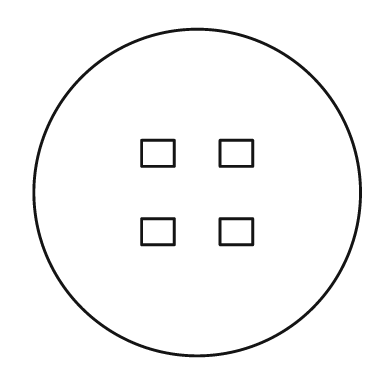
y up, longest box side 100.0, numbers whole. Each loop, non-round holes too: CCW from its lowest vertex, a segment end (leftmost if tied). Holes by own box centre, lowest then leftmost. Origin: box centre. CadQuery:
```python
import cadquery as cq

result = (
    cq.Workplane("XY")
    .moveTo(0.0, 0.0)
    .circle(50.0)
    .moveTo(-17.0, -16.0)
    .lineTo(-7.0, -16.0)
    .lineTo(-7.0, -8.0)
    .lineTo(-17.0, -8.0)
    .close()
    .moveTo(7.0, -16.0)
    .lineTo(17.0, -16.0)
    .lineTo(17.0, -8.0)
    .lineTo(7.0, -8.0)
    .close()
    .moveTo(-17.0, 8.0)
    .lineTo(-7.0, 8.0)
    .lineTo(-7.0, 16.0)
    .lineTo(-17.0, 16.0)
    .close()
    .moveTo(7.0, 8.0)
    .lineTo(17.0, 8.0)
    .lineTo(17.0, 16.0)
    .lineTo(7.0, 16.0)
    .close()
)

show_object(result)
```